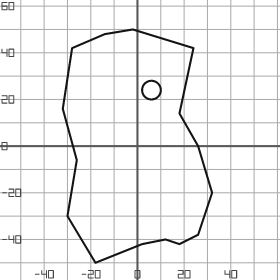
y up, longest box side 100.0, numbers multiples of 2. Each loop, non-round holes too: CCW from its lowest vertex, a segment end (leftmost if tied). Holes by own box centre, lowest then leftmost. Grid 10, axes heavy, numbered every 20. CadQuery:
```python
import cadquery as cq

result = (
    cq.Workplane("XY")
    .moveTo(-18.0, -50.0)
    .lineTo(2.0, -42.0)
    .lineTo(12.0, -40.0)
    .lineTo(18.0, -42.0)
    .lineTo(26.0, -38.0)
    .lineTo(32.0, -20.0)
    .lineTo(26.0, 0.0)
    .lineTo(18.0, 14.0)
    .lineTo(24.0, 42.0)
    .lineTo(-2.0, 50.0)
    .lineTo(-14.0, 48.0)
    .lineTo(-28.0, 42.0)
    .lineTo(-32.0, 16.0)
    .lineTo(-26.0, -6.0)
    .lineTo(-30.0, -30.0)
    .close()
    .moveTo(6.0, 24.0)
    .circle(4.0)
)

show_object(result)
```